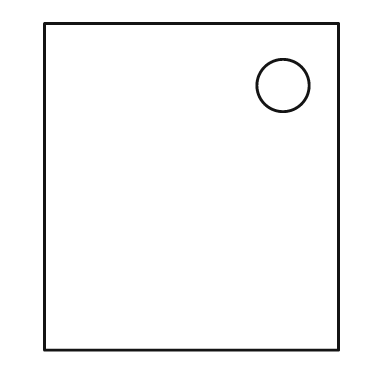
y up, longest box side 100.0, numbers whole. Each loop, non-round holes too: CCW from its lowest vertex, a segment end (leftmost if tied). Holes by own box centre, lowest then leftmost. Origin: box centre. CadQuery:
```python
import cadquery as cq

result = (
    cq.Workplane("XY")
    .moveTo(-45.0, -50.0)
    .lineTo(45.0, -50.0)
    .lineTo(45.0, 50.0)
    .lineTo(-45.0, 50.0)
    .close()
    .moveTo(28.0, 31.0)
    .circle(8.0)
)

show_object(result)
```